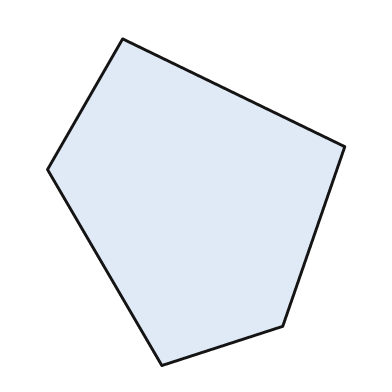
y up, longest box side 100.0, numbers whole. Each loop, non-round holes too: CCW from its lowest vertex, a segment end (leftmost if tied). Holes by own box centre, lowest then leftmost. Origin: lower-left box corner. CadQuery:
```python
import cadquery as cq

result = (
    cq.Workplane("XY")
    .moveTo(35.0, 0.0)
    .lineTo(72.0, 12.0)
    .lineTo(91.0, 67.0)
    .lineTo(23.0, 100.0)
    .lineTo(0.0, 60.0)
    .close()
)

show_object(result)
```